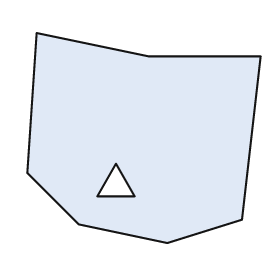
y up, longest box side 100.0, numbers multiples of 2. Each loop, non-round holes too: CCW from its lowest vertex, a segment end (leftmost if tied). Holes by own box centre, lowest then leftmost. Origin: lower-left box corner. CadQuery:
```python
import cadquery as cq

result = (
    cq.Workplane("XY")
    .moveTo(60.0, 0.0)
    .lineTo(92.0, 10.0)
    .lineTo(100.0, 80.0)
    .lineTo(52.0, 80.0)
    .lineTo(4.0, 90.0)
    .lineTo(0.0, 30.0)
    .lineTo(22.0, 8.0)
    .close()
    .moveTo(30.0, 20.0)
    .lineTo(46.0, 20.0)
    .lineTo(38.0, 34.0)
    .close()
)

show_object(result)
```